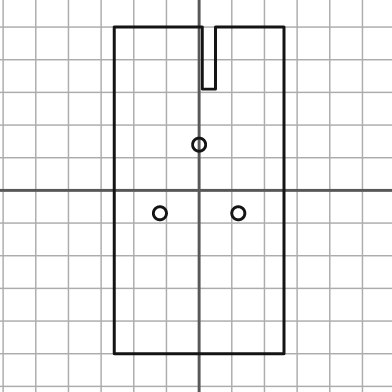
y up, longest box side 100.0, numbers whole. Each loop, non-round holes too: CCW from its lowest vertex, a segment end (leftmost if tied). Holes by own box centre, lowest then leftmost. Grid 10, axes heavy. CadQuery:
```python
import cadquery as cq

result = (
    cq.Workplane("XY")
    .moveTo(-26.0, -50.0)
    .lineTo(26.0, -50.0)
    .lineTo(26.0, 50.0)
    .lineTo(5.0, 50.0)
    .lineTo(5.0, 31.0)
    .lineTo(1.0, 31.0)
    .lineTo(1.0, 50.0)
    .lineTo(-26.0, 50.0)
    .close()
    .moveTo(-12.0, -7.0)
    .circle(2.0)
    .moveTo(12.0, -7.0)
    .circle(2.0)
    .moveTo(0.0, 14.0)
    .circle(2.0)
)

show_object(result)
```